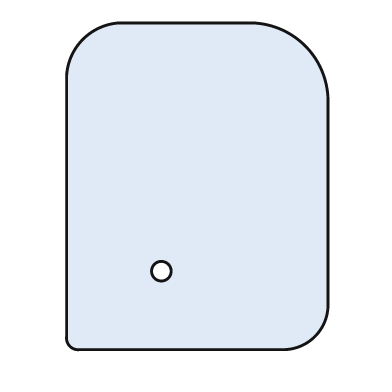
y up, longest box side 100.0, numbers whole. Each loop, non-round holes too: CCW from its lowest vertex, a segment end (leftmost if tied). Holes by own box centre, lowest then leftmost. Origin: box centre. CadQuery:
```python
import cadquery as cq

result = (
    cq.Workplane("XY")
    .moveTo(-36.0, -50.0)
    .lineTo(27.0, -50.0)
    .threePointArc((36.0, -46.0), (40.0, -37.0))
    .lineTo(40.0, 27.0)
    .threePointArc((33.0, 43.0), (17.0, 50.0))
    .lineTo(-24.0, 50.0)
    .threePointArc((-35.0, 45.0), (-40.0, 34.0))
    .lineTo(-40.0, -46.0)
    .threePointArc((-39.0, -49.0), (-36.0, -50.0))
    .close()
    .moveTo(-11.0, -26.0)
    .circle(3.0)
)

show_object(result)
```